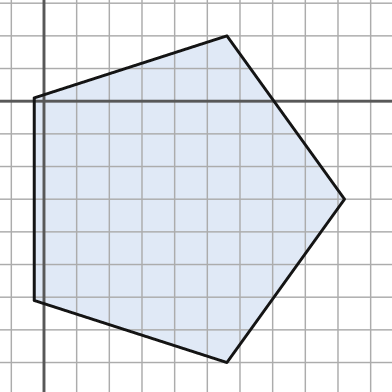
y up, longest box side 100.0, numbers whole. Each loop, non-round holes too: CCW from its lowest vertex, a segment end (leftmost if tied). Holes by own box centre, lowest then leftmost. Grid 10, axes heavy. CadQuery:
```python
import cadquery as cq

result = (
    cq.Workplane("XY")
    .moveTo(56.0, -80.0)
    .lineTo(92.0, -30.0)
    .lineTo(56.0, 20.0)
    .lineTo(-3.0, 1.0)
    .lineTo(-3.0, -61.0)
    .close()
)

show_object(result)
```